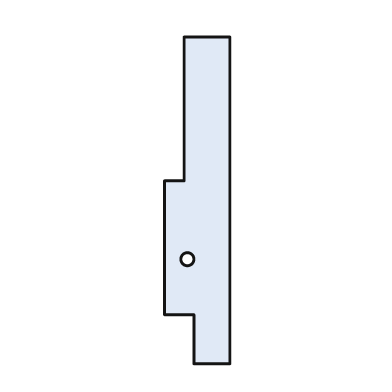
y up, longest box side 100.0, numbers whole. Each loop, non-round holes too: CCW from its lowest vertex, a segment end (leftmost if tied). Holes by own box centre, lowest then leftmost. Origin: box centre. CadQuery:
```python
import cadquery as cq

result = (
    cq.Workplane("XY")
    .moveTo(-1.0, -50.0)
    .lineTo(10.0, -50.0)
    .lineTo(10.0, 50.0)
    .lineTo(-4.0, 50.0)
    .lineTo(-4.0, 6.0)
    .lineTo(-10.0, 6.0)
    .lineTo(-10.0, -35.0)
    .lineTo(-1.0, -35.0)
    .close()
    .moveTo(-3.0, -18.0)
    .circle(2.0)
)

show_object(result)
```